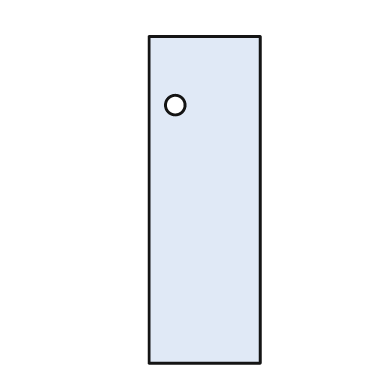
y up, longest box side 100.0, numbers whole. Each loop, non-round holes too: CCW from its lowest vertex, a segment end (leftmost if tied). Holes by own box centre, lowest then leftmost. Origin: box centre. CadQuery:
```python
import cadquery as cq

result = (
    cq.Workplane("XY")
    .moveTo(-17.0, -50.0)
    .lineTo(17.0, -50.0)
    .lineTo(17.0, 50.0)
    .lineTo(-17.0, 50.0)
    .close()
    .moveTo(-9.0, 29.0)
    .circle(3.0)
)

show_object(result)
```